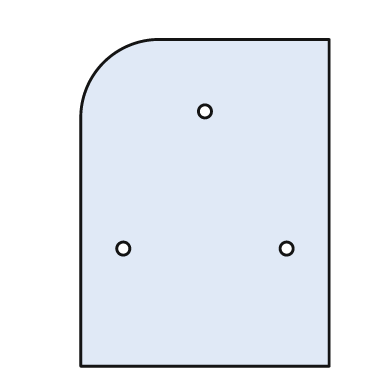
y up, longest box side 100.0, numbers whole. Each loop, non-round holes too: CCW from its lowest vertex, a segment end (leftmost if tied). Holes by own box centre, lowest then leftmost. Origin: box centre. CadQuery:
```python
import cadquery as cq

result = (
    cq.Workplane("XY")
    .moveTo(-38.0, -50.0)
    .lineTo(38.0, -50.0)
    .lineTo(38.0, 50.0)
    .lineTo(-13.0, 50.0)
    .threePointArc((-31.0, 43.0), (-38.0, 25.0))
    .close()
    .moveTo(-25.0, -14.0)
    .circle(2.0)
    .moveTo(25.0, -14.0)
    .circle(2.0)
    .moveTo(0.0, 28.0)
    .circle(2.0)
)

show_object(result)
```